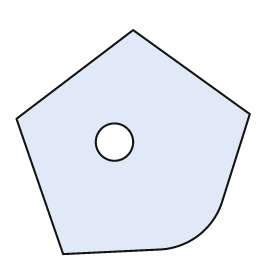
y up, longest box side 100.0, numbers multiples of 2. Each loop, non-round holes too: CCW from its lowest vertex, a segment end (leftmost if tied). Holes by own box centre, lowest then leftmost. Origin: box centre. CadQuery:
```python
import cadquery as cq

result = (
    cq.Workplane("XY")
    .moveTo(-30.0, -48.0)
    .lineTo(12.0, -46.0)
    .threePointArc((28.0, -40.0), (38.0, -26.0))
    .lineTo(50.0, 12.0)
    .lineTo(0.0, 48.0)
    .lineTo(-50.0, 10.0)
    .close()
    .moveTo(-8.0, 0.0)
    .circle(8.0)
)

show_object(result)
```